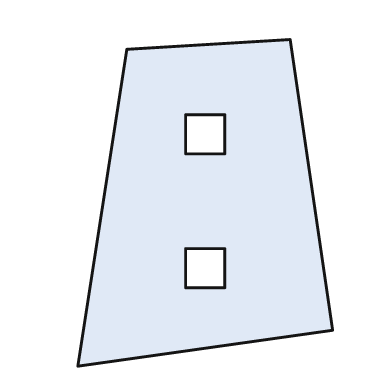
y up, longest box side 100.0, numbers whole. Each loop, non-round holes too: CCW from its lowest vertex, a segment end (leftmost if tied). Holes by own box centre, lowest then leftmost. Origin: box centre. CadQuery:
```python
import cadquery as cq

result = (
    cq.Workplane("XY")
    .moveTo(-39.0, -50.0)
    .lineTo(39.0, -39.0)
    .lineTo(26.0, 50.0)
    .lineTo(-24.0, 47.0)
    .close()
    .moveTo(-6.0, -26.0)
    .lineTo(6.0, -26.0)
    .lineTo(6.0, -14.0)
    .lineTo(-6.0, -14.0)
    .close()
    .moveTo(-6.0, 15.0)
    .lineTo(6.0, 15.0)
    .lineTo(6.0, 27.0)
    .lineTo(-6.0, 27.0)
    .close()
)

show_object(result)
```